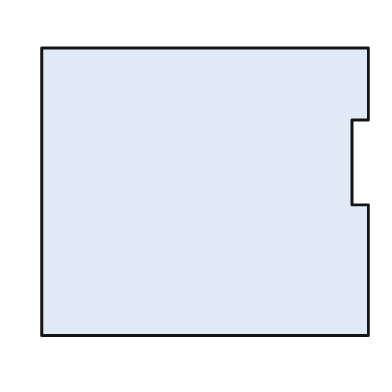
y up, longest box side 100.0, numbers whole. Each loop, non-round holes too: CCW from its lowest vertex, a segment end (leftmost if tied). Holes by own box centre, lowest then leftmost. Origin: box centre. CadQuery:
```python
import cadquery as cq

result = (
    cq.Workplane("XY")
    .moveTo(-50.0, -44.0)
    .lineTo(50.0, -44.0)
    .lineTo(50.0, -4.0)
    .lineTo(45.0, -4.0)
    .lineTo(45.0, 22.0)
    .lineTo(50.0, 22.0)
    .lineTo(50.0, 44.0)
    .lineTo(-50.0, 44.0)
    .close()
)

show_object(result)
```